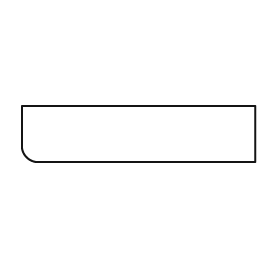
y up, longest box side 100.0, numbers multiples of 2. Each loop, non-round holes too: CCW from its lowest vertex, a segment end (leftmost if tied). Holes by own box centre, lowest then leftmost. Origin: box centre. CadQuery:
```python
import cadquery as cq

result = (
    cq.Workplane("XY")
    .moveTo(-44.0, -12.0)
    .lineTo(50.0, -12.0)
    .lineTo(50.0, 12.0)
    .lineTo(-50.0, 12.0)
    .lineTo(-50.0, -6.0)
    .threePointArc((-48.0, -10.0), (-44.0, -12.0))
    .close()
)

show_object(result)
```